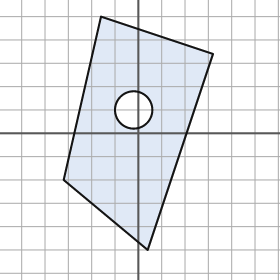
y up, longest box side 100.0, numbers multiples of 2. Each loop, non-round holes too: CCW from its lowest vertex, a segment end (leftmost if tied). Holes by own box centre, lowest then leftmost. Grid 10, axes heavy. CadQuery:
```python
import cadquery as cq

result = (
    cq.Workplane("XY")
    .moveTo(4.0, -50.0)
    .lineTo(32.0, 34.0)
    .lineTo(-16.0, 50.0)
    .lineTo(-32.0, -20.0)
    .close()
    .moveTo(-2.0, 10.0)
    .circle(8.0)
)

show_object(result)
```